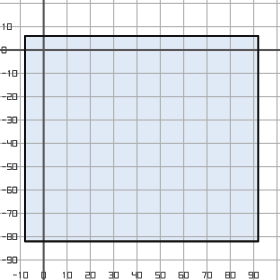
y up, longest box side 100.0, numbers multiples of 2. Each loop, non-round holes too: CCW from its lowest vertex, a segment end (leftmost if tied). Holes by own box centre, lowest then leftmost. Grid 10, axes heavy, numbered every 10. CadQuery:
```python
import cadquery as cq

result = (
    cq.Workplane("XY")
    .moveTo(-8.0, -82.0)
    .lineTo(92.0, -82.0)
    .lineTo(92.0, 6.0)
    .lineTo(-8.0, 6.0)
    .close()
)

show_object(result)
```